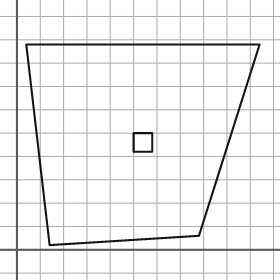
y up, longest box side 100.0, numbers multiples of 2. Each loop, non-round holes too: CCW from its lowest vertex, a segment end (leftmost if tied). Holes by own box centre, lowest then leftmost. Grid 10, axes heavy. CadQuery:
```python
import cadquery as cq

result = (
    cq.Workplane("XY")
    .moveTo(14.0, 2.0)
    .lineTo(78.0, 6.0)
    .lineTo(104.0, 88.0)
    .lineTo(4.0, 88.0)
    .close()
    .moveTo(50.0, 42.0)
    .lineTo(58.0, 42.0)
    .lineTo(58.0, 50.0)
    .lineTo(50.0, 50.0)
    .close()
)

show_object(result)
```